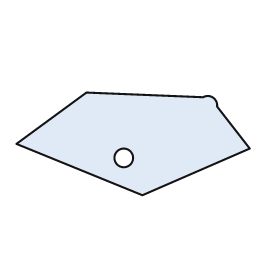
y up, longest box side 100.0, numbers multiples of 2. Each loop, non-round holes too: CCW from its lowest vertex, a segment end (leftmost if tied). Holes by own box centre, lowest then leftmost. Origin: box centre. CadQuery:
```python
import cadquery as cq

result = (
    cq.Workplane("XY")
    .moveTo(4.0, -22.0)
    .lineTo(50.0, -2.0)
    .lineTo(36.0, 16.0)
    .threePointArc((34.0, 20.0), (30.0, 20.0))
    .lineTo(-20.0, 22.0)
    .lineTo(-50.0, 0.0)
    .close()
    .moveTo(-4.0, -6.0)
    .circle(4.0)
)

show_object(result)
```